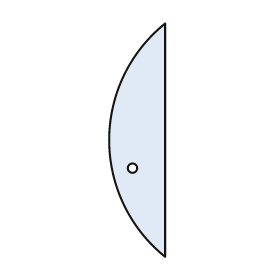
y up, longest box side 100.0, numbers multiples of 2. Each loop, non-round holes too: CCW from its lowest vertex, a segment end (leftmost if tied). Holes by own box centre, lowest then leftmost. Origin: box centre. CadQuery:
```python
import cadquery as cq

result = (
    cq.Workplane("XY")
    .moveTo(12.0, -50.0)
    .lineTo(12.0, 50.0)
    .threePointArc((-12.0, 0.0), (12.0, -50.0))
    .close()
    .moveTo(-2.0, -12.0)
    .circle(2.0)
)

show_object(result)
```